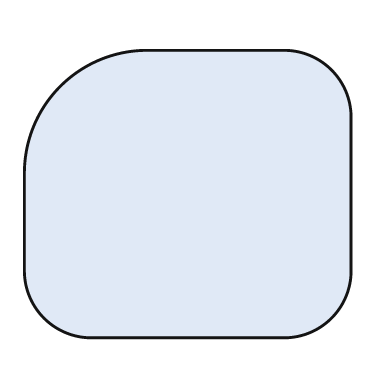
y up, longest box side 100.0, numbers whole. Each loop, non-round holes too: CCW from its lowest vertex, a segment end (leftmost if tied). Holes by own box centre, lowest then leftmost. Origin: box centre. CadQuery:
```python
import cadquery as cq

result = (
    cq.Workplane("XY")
    .moveTo(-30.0, -44.0)
    .lineTo(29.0, -44.0)
    .threePointArc((44.0, -38.0), (50.0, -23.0))
    .lineTo(50.0, 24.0)
    .threePointArc((44.0, 38.0), (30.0, 44.0))
    .lineTo(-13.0, 44.0)
    .threePointArc((-39.0, 33.0), (-50.0, 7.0))
    .lineTo(-50.0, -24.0)
    .threePointArc((-44.0, -38.0), (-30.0, -44.0))
    .close()
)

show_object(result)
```